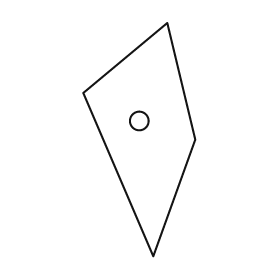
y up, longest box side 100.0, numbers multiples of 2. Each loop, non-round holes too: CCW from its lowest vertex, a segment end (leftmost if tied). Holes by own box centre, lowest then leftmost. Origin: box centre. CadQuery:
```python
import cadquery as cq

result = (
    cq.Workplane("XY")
    .moveTo(6.0, -50.0)
    .lineTo(24.0, 0.0)
    .lineTo(12.0, 50.0)
    .lineTo(-24.0, 20.0)
    .close()
    .moveTo(0.0, 8.0)
    .circle(4.0)
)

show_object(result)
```